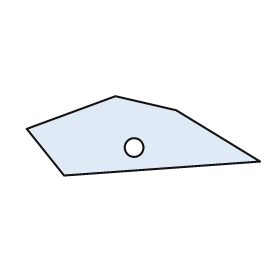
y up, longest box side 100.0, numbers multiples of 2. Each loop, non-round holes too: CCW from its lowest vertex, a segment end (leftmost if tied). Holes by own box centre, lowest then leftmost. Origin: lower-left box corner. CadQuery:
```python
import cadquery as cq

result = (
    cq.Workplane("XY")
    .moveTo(16.0, 0.0)
    .lineTo(100.0, 6.0)
    .lineTo(64.0, 28.0)
    .lineTo(38.0, 34.0)
    .lineTo(0.0, 20.0)
    .close()
    .moveTo(46.0, 12.0)
    .circle(4.0)
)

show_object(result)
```